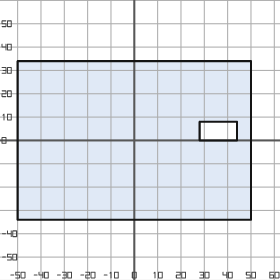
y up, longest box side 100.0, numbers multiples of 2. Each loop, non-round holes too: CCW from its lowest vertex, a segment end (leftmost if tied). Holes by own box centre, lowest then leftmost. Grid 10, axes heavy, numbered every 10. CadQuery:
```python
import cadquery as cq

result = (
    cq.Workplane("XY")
    .moveTo(-50.0, -34.0)
    .lineTo(50.0, -34.0)
    .lineTo(50.0, 34.0)
    .lineTo(-50.0, 34.0)
    .close()
    .moveTo(28.0, 0.0)
    .lineTo(44.0, 0.0)
    .lineTo(44.0, 8.0)
    .lineTo(28.0, 8.0)
    .close()
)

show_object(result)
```